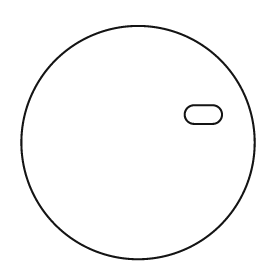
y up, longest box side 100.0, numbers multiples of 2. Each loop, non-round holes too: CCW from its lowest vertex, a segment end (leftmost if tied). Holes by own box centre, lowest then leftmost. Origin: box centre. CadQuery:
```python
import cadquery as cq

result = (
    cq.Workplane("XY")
    .moveTo(0.0, 0.0)
    .circle(50.0)
    .moveTo(24.0, 8.0)
    .lineTo(32.0, 8.0)
    .threePointArc((36.0, 12.0), (32.0, 16.0))
    .lineTo(24.0, 16.0)
    .threePointArc((20.0, 12.0), (24.0, 8.0))
    .close()
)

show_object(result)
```